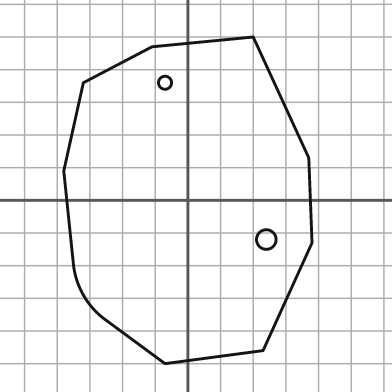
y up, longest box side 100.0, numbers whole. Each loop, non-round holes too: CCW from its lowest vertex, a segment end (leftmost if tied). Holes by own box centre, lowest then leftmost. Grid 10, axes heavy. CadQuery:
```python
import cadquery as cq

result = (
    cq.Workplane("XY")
    .moveTo(-7.0, -50.0)
    .lineTo(23.0, -46.0)
    .lineTo(38.0, -13.0)
    .lineTo(37.0, 13.0)
    .lineTo(20.0, 50.0)
    .lineTo(-11.0, 47.0)
    .lineTo(-32.0, 36.0)
    .lineTo(-38.0, 9.0)
    .lineTo(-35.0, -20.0)
    .threePointArc((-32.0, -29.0), (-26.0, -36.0))
    .close()
    .moveTo(24.0, -12.0)
    .circle(3.0)
    .moveTo(-7.0, 36.0)
    .circle(2.0)
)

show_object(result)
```